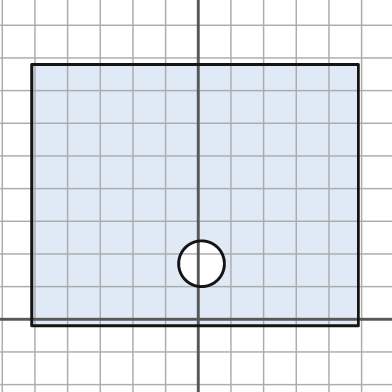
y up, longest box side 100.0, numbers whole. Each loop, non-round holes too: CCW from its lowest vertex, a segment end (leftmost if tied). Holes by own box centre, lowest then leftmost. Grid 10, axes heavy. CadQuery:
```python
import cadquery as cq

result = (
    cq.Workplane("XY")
    .moveTo(-51.0, -2.0)
    .lineTo(49.0, -2.0)
    .lineTo(49.0, 78.0)
    .lineTo(-51.0, 78.0)
    .close()
    .moveTo(1.0, 17.0)
    .circle(7.0)
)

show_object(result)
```